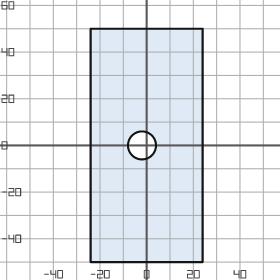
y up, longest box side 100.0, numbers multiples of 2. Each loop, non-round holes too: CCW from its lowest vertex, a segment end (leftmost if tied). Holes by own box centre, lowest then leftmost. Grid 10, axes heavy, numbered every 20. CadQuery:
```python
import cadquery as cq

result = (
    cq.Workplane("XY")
    .moveTo(-24.0, -50.0)
    .lineTo(24.0, -50.0)
    .lineTo(24.0, 50.0)
    .lineTo(-24.0, 50.0)
    .close()
    .moveTo(-2.0, 0.0)
    .circle(6.0)
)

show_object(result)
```